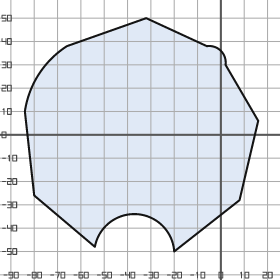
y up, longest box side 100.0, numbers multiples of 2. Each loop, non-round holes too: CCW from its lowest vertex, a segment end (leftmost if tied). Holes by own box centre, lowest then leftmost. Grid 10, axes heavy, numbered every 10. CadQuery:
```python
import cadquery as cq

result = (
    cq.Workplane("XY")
    .moveTo(-20.0, -50.0)
    .lineTo(8.0, -28.0)
    .lineTo(16.0, 6.0)
    .lineTo(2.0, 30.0)
    .threePointArc((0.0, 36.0), (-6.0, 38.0))
    .lineTo(-32.0, 50.0)
    .lineTo(-66.0, 38.0)
    .threePointArc((-78.0, 26.0), (-84.0, 10.0))
    .lineTo(-80.0, -26.0)
    .lineTo(-54.0, -48.0)
    .threePointArc((-36.0, -34.0), (-20.0, -50.0))
    .close()
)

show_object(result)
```